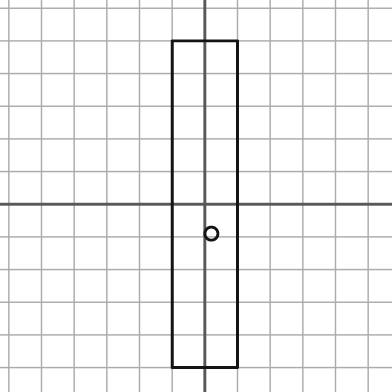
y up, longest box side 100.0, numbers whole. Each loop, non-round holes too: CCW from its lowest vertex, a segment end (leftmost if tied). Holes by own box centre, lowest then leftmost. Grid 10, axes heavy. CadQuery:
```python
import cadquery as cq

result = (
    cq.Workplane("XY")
    .moveTo(-10.0, -50.0)
    .lineTo(10.0, -50.0)
    .lineTo(10.0, 50.0)
    .lineTo(-10.0, 50.0)
    .close()
    .moveTo(2.0, -9.0)
    .circle(2.0)
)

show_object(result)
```